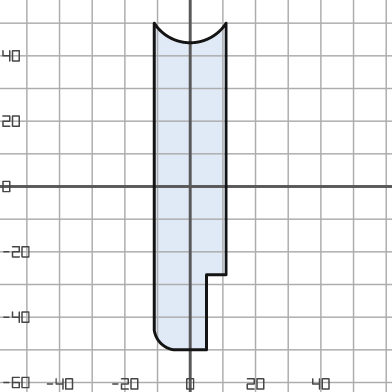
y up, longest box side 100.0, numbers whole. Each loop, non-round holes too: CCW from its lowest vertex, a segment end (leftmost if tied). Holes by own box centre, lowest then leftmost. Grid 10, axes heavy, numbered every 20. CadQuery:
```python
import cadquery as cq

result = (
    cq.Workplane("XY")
    .moveTo(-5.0, -50.0)
    .lineTo(5.0, -50.0)
    .lineTo(5.0, -27.0)
    .lineTo(11.0, -27.0)
    .lineTo(11.0, 50.0)
    .threePointArc((0.0, 44.0), (-11.0, 50.0))
    .lineTo(-11.0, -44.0)
    .threePointArc((-9.0, -48.0), (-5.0, -50.0))
    .close()
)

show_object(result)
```